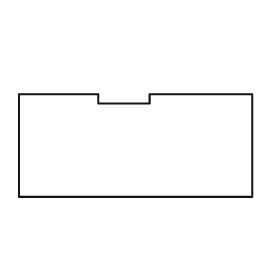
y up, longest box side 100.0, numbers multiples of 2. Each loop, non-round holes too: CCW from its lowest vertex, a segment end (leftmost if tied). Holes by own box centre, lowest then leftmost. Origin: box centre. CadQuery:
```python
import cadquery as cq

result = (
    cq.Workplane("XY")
    .moveTo(-50.0, -22.0)
    .lineTo(50.0, -22.0)
    .lineTo(50.0, 22.0)
    .lineTo(6.0, 22.0)
    .lineTo(6.0, 18.0)
    .lineTo(-16.0, 18.0)
    .lineTo(-16.0, 22.0)
    .lineTo(-50.0, 22.0)
    .close()
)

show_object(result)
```